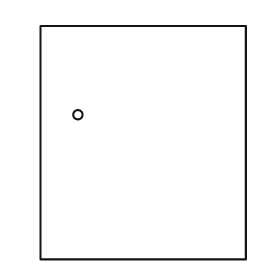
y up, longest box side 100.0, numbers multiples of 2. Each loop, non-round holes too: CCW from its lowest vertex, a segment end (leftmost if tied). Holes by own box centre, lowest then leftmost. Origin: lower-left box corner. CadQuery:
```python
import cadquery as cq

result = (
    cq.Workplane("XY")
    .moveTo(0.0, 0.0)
    .lineTo(88.0, 0.0)
    .lineTo(88.0, 100.0)
    .lineTo(0.0, 100.0)
    .close()
    .moveTo(16.0, 62.0)
    .circle(2.0)
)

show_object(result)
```